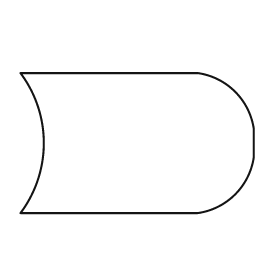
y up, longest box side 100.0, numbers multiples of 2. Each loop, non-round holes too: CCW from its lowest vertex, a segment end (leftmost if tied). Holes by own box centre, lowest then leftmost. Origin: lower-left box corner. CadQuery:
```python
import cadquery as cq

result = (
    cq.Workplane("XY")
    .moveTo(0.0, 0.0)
    .lineTo(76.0, 0.0)
    .threePointArc((92.0, 8.0), (100.0, 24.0))
    .lineTo(100.0, 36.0)
    .threePointArc((92.0, 52.0), (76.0, 60.0))
    .lineTo(0.0, 60.0)
    .threePointArc((10.0, 30.0), (0.0, 0.0))
    .close()
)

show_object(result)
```